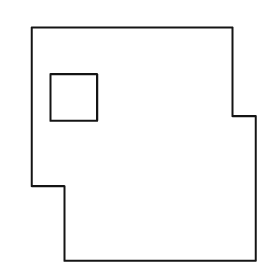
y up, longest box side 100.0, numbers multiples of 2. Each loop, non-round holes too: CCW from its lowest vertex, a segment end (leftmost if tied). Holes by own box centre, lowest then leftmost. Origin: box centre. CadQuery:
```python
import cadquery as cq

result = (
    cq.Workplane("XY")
    .moveTo(-34.0, -50.0)
    .lineTo(48.0, -50.0)
    .lineTo(48.0, 12.0)
    .lineTo(38.0, 12.0)
    .lineTo(38.0, 50.0)
    .lineTo(-48.0, 50.0)
    .lineTo(-48.0, -18.0)
    .lineTo(-34.0, -18.0)
    .close()
    .moveTo(-40.0, 10.0)
    .lineTo(-20.0, 10.0)
    .lineTo(-20.0, 30.0)
    .lineTo(-40.0, 30.0)
    .close()
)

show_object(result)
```